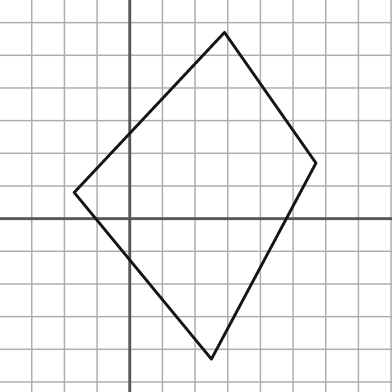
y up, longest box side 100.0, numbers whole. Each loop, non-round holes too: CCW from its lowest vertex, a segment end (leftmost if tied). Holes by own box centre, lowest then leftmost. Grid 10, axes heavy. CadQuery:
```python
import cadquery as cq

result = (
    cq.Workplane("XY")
    .moveTo(25.0, -43.0)
    .lineTo(57.0, 17.0)
    .lineTo(29.0, 57.0)
    .lineTo(-17.0, 8.0)
    .close()
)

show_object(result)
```